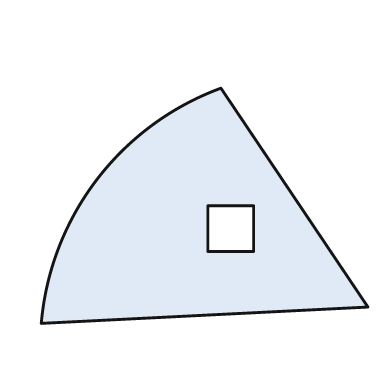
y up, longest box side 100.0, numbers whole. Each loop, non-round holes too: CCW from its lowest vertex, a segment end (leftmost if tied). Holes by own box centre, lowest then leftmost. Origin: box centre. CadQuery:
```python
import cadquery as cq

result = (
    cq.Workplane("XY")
    .moveTo(-50.0, -36.0)
    .lineTo(50.0, -31.0)
    .lineTo(5.0, 36.0)
    .threePointArc((-33.0, 8.0), (-50.0, -36.0))
    .close()
    .moveTo(1.0, -14.0)
    .lineTo(15.0, -14.0)
    .lineTo(15.0, 0.0)
    .lineTo(1.0, 0.0)
    .close()
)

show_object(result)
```